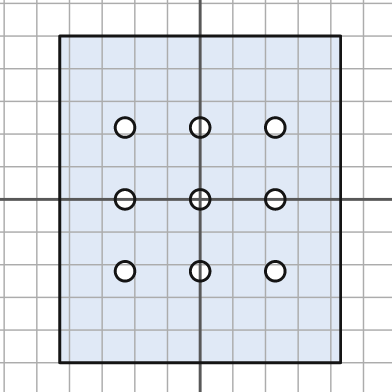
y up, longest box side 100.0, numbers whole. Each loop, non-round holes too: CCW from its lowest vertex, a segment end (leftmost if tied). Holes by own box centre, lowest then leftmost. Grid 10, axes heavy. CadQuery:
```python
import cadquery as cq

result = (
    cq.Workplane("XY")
    .moveTo(-43.0, -50.0)
    .lineTo(43.0, -50.0)
    .lineTo(43.0, 50.0)
    .lineTo(-43.0, 50.0)
    .close()
    .moveTo(-23.0, -22.0)
    .circle(3.0)
    .moveTo(0.0, -22.0)
    .circle(3.0)
    .moveTo(23.0, -22.0)
    .circle(3.0)
    .moveTo(-23.0, 0.0)
    .circle(3.0)
    .moveTo(0.0, 0.0)
    .circle(3.0)
    .moveTo(23.0, 0.0)
    .circle(3.0)
    .moveTo(-23.0, 22.0)
    .circle(3.0)
    .moveTo(0.0, 22.0)
    .circle(3.0)
    .moveTo(23.0, 22.0)
    .circle(3.0)
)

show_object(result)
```